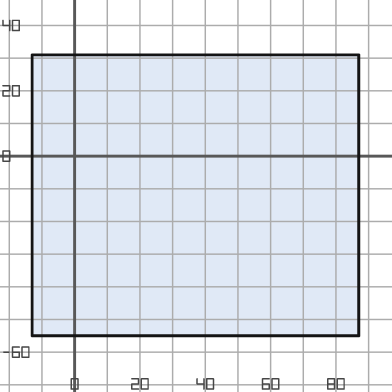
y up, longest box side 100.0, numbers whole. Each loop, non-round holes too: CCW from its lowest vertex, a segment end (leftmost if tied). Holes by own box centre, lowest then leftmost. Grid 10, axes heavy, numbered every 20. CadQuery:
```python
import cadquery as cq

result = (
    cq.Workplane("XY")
    .moveTo(-13.0, -55.0)
    .lineTo(87.0, -55.0)
    .lineTo(87.0, 31.0)
    .lineTo(-13.0, 31.0)
    .close()
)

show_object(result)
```